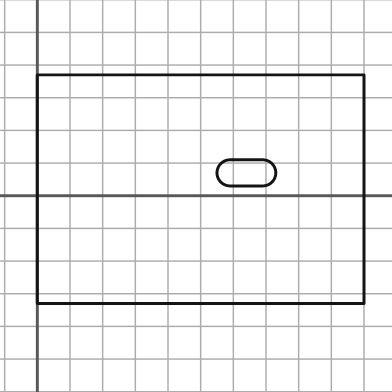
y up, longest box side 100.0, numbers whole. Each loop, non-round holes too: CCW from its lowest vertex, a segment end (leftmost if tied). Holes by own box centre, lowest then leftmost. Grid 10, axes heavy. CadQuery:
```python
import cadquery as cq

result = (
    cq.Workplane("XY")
    .moveTo(0.0, -33.0)
    .lineTo(100.0, -33.0)
    .lineTo(100.0, 37.0)
    .lineTo(0.0, 37.0)
    .close()
    .moveTo(59.0, 3.0)
    .lineTo(69.0, 3.0)
    .threePointArc((73.0, 7.0), (69.0, 11.0))
    .lineTo(59.0, 11.0)
    .threePointArc((55.0, 7.0), (59.0, 3.0))
    .close()
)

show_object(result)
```